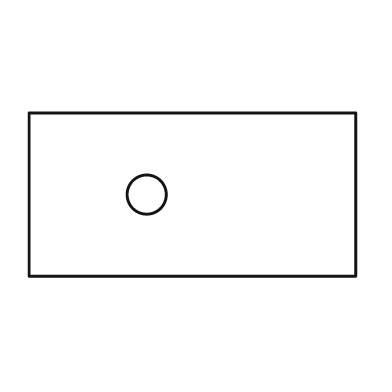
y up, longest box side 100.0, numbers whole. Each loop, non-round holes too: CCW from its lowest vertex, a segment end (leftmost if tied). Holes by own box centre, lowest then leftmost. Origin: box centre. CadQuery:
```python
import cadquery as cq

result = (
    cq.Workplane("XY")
    .moveTo(-50.0, -25.0)
    .lineTo(50.0, -25.0)
    .lineTo(50.0, 25.0)
    .lineTo(-50.0, 25.0)
    .close()
    .moveTo(-14.0, 0.0)
    .circle(6.0)
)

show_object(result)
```